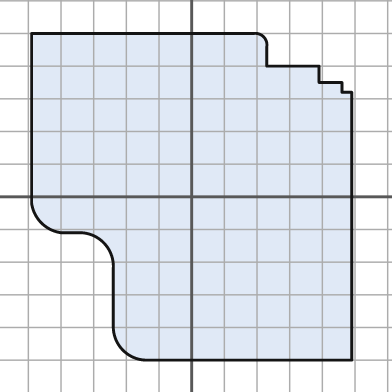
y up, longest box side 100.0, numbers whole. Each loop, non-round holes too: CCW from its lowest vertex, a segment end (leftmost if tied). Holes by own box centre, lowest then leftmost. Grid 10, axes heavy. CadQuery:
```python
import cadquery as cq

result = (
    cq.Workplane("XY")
    .moveTo(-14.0, -50.0)
    .lineTo(49.0, -50.0)
    .lineTo(49.0, 32.0)
    .lineTo(46.0, 32.0)
    .lineTo(46.0, 35.0)
    .lineTo(39.0, 35.0)
    .lineTo(39.0, 40.0)
    .lineTo(23.0, 40.0)
    .lineTo(23.0, 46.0)
    .threePointArc((22.0, 49.0), (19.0, 50.0))
    .lineTo(-49.0, 50.0)
    .lineTo(-49.0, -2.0)
    .threePointArc((-46.0, -8.0), (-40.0, -11.0))
    .lineTo(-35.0, -11.0)
    .threePointArc((-27.0, -14.0), (-24.0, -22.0))
    .lineTo(-24.0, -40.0)
    .threePointArc((-21.0, -47.0), (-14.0, -50.0))
    .close()
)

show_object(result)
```